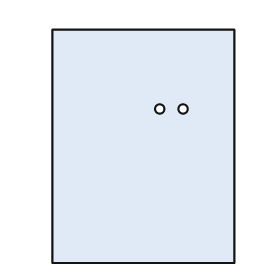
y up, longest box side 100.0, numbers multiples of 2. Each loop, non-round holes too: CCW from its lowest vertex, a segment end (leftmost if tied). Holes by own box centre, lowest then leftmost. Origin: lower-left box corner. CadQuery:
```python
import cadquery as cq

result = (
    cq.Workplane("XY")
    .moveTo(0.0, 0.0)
    .lineTo(78.0, 0.0)
    .lineTo(78.0, 100.0)
    .lineTo(0.0, 100.0)
    .close()
    .moveTo(46.0, 66.0)
    .circle(2.0)
    .moveTo(56.0, 66.0)
    .circle(2.0)
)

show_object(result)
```